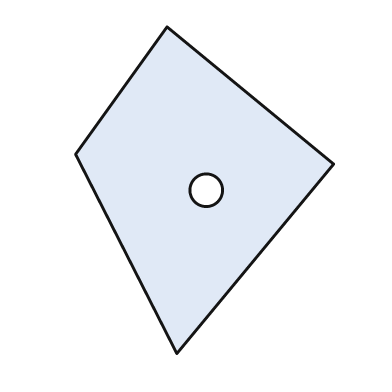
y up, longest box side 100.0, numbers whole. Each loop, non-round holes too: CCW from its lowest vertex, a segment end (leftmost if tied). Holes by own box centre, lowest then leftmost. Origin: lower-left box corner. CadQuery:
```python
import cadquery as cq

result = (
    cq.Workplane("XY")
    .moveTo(31.0, 0.0)
    .lineTo(79.0, 58.0)
    .lineTo(28.0, 100.0)
    .lineTo(0.0, 61.0)
    .close()
    .moveTo(40.0, 50.0)
    .circle(5.0)
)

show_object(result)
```